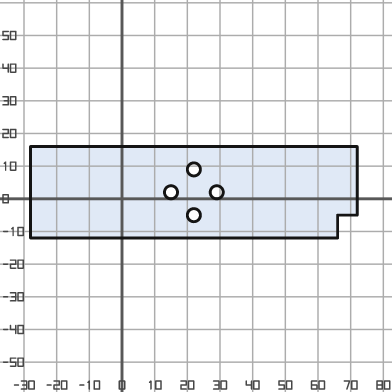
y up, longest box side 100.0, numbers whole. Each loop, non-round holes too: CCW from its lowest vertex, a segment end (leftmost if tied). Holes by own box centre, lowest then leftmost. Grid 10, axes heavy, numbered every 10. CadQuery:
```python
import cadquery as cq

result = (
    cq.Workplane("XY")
    .moveTo(-28.0, -12.0)
    .lineTo(66.0, -12.0)
    .lineTo(66.0, -5.0)
    .lineTo(72.0, -5.0)
    .lineTo(72.0, 16.0)
    .lineTo(-28.0, 16.0)
    .close()
    .moveTo(22.0, -5.0)
    .circle(2.0)
    .moveTo(15.0, 2.0)
    .circle(2.0)
    .moveTo(29.0, 2.0)
    .circle(2.0)
    .moveTo(22.0, 9.0)
    .circle(2.0)
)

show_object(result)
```